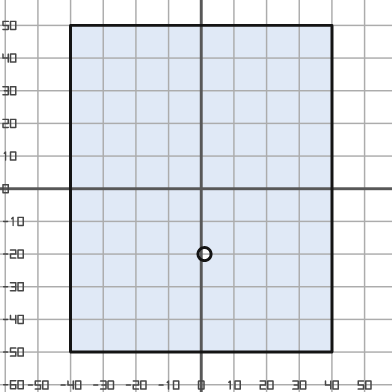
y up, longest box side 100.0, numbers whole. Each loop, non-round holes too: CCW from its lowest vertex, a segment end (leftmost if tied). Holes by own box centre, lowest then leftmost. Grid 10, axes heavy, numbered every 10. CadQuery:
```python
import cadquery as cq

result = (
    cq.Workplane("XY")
    .moveTo(-40.0, -50.0)
    .lineTo(40.0, -50.0)
    .lineTo(40.0, 50.0)
    .lineTo(-40.0, 50.0)
    .close()
    .moveTo(1.0, -20.0)
    .circle(2.0)
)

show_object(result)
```